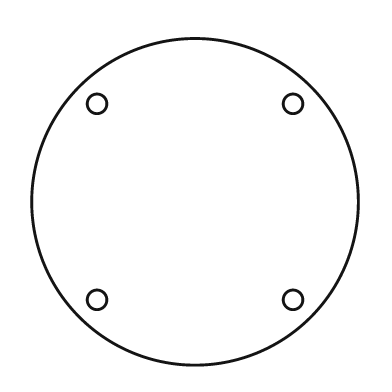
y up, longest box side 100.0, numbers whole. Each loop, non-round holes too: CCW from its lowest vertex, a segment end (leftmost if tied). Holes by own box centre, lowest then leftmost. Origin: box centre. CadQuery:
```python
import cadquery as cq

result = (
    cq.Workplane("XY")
    .moveTo(0.0, 0.0)
    .circle(50.0)
    .moveTo(-30.0, -30.0)
    .circle(3.0)
    .moveTo(30.0, -30.0)
    .circle(3.0)
    .moveTo(-30.0, 30.0)
    .circle(3.0)
    .moveTo(30.0, 30.0)
    .circle(3.0)
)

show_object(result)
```